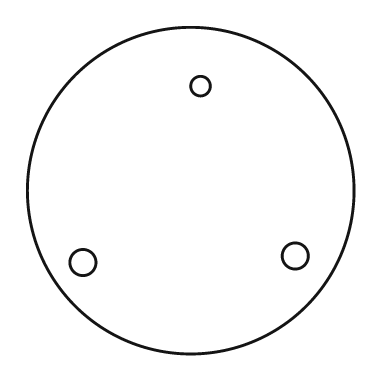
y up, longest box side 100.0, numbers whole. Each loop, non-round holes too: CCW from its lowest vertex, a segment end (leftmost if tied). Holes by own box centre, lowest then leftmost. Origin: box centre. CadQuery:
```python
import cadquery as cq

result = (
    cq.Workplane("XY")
    .moveTo(0.0, 0.0)
    .circle(50.0)
    .moveTo(-33.0, -22.0)
    .circle(4.0)
    .moveTo(32.0, -20.0)
    .circle(4.0)
    .moveTo(3.0, 32.0)
    .circle(3.0)
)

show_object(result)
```